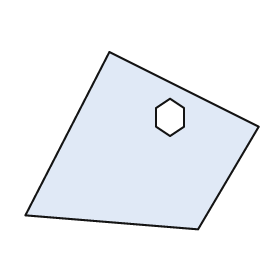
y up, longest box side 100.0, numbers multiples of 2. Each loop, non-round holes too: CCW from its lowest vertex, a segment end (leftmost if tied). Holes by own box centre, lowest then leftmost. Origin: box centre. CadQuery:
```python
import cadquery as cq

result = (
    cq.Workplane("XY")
    .moveTo(24.0, -38.0)
    .lineTo(50.0, 6.0)
    .lineTo(-14.0, 38.0)
    .lineTo(-50.0, -32.0)
    .close()
    .moveTo(12.0, 2.0)
    .lineTo(18.0, 6.0)
    .lineTo(18.0, 14.0)
    .lineTo(12.0, 18.0)
    .lineTo(6.0, 14.0)
    .lineTo(6.0, 6.0)
    .close()
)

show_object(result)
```